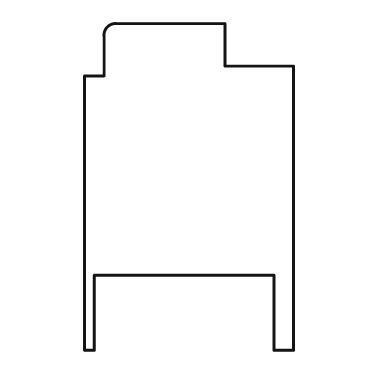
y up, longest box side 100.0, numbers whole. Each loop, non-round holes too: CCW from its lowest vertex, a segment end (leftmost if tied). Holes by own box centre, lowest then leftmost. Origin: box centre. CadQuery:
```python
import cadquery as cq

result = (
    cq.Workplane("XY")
    .moveTo(-32.0, -50.0)
    .lineTo(-29.0, -50.0)
    .lineTo(-29.0, -27.0)
    .lineTo(26.0, -27.0)
    .lineTo(26.0, -50.0)
    .lineTo(32.0, -50.0)
    .lineTo(32.0, 37.0)
    .lineTo(11.0, 37.0)
    .lineTo(11.0, 50.0)
    .lineTo(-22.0, 50.0)
    .threePointArc((-25.0, 49.0), (-26.0, 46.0))
    .lineTo(-26.0, 34.0)
    .lineTo(-32.0, 34.0)
    .close()
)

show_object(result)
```